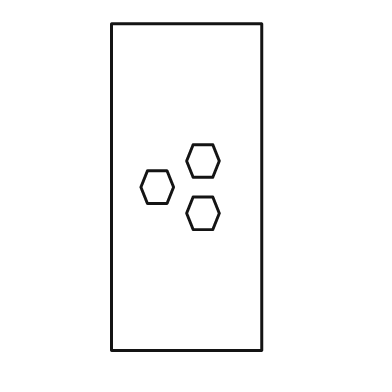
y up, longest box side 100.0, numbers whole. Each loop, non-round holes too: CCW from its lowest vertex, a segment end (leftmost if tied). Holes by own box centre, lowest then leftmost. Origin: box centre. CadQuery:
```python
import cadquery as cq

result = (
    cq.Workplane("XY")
    .moveTo(-23.0, -50.0)
    .lineTo(23.0, -50.0)
    .lineTo(23.0, 50.0)
    .lineTo(-23.0, 50.0)
    .close()
    .moveTo(2.0, -13.0)
    .lineTo(8.0, -13.0)
    .lineTo(10.0, -8.0)
    .lineTo(8.0, -3.0)
    .lineTo(2.0, -3.0)
    .lineTo(0.0, -8.0)
    .close()
    .moveTo(-12.0, -5.0)
    .lineTo(-6.0, -5.0)
    .lineTo(-4.0, 0.0)
    .lineTo(-6.0, 5.0)
    .lineTo(-12.0, 5.0)
    .lineTo(-14.0, 0.0)
    .close()
    .moveTo(2.0, 3.0)
    .lineTo(8.0, 3.0)
    .lineTo(10.0, 8.0)
    .lineTo(8.0, 13.0)
    .lineTo(2.0, 13.0)
    .lineTo(0.0, 8.0)
    .close()
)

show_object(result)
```